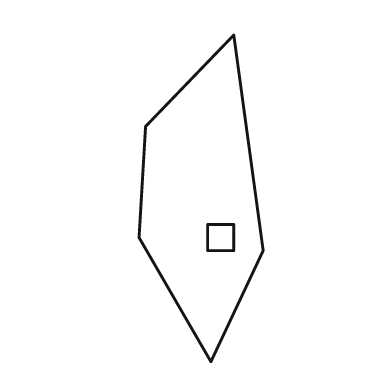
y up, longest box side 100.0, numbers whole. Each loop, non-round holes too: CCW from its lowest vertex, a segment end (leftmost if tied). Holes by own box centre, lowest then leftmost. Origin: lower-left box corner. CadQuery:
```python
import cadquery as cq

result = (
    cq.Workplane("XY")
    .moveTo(22.0, 0.0)
    .lineTo(38.0, 34.0)
    .lineTo(29.0, 100.0)
    .lineTo(2.0, 72.0)
    .lineTo(0.0, 38.0)
    .close()
    .moveTo(21.0, 34.0)
    .lineTo(29.0, 34.0)
    .lineTo(29.0, 42.0)
    .lineTo(21.0, 42.0)
    .close()
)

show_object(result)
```